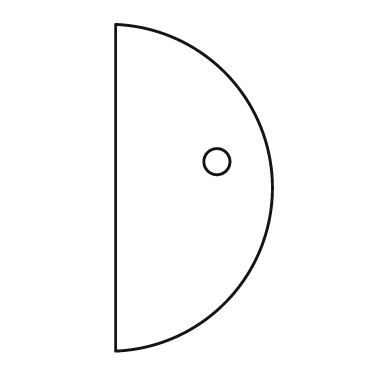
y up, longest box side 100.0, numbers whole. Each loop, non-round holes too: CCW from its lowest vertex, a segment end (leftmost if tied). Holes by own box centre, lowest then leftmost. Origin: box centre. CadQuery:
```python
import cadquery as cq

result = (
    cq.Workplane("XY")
    .moveTo(-24.0, -50.0)
    .threePointArc((24.0, 0.0), (-24.0, 50.0))
    .close()
    .moveTo(7.0, 8.0)
    .circle(4.0)
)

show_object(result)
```